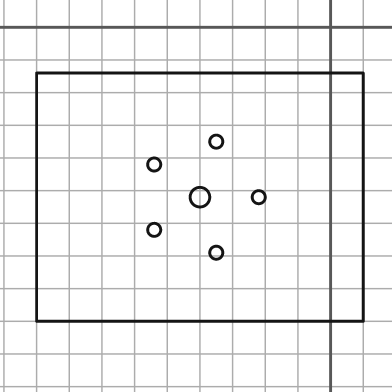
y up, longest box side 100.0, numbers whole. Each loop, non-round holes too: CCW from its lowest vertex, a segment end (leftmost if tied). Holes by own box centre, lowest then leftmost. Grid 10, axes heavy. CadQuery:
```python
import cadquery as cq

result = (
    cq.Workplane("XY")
    .moveTo(-90.0, -90.0)
    .lineTo(10.0, -90.0)
    .lineTo(10.0, -14.0)
    .lineTo(-90.0, -14.0)
    .close()
    .moveTo(-35.0, -69.0)
    .circle(2.0)
    .moveTo(-54.0, -62.0)
    .circle(2.0)
    .moveTo(-40.0, -52.0)
    .circle(3.0)
    .moveTo(-22.0, -52.0)
    .circle(2.0)
    .moveTo(-54.0, -42.0)
    .circle(2.0)
    .moveTo(-35.0, -35.0)
    .circle(2.0)
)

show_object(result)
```